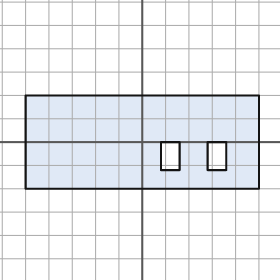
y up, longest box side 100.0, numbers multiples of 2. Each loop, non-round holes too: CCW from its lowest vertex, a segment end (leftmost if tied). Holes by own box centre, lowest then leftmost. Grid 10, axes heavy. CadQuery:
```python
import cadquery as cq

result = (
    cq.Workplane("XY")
    .moveTo(-50.0, -20.0)
    .lineTo(50.0, -20.0)
    .lineTo(50.0, 20.0)
    .lineTo(-50.0, 20.0)
    .close()
    .moveTo(8.0, -12.0)
    .lineTo(16.0, -12.0)
    .lineTo(16.0, 0.0)
    .lineTo(8.0, 0.0)
    .close()
    .moveTo(28.0, -12.0)
    .lineTo(36.0, -12.0)
    .lineTo(36.0, 0.0)
    .lineTo(28.0, 0.0)
    .close()
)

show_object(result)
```